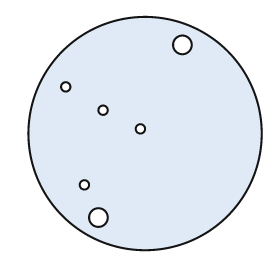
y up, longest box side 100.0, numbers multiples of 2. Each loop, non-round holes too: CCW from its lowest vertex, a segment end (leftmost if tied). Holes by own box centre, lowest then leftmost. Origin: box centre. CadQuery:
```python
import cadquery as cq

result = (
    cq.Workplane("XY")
    .moveTo(0.0, 0.0)
    .circle(50.0)
    .moveTo(-20.0, -36.0)
    .circle(4.0)
    .moveTo(-26.0, -22.0)
    .circle(2.0)
    .moveTo(-2.0, 2.0)
    .circle(2.0)
    .moveTo(-18.0, 10.0)
    .circle(2.0)
    .moveTo(-34.0, 20.0)
    .circle(2.0)
    .moveTo(16.0, 38.0)
    .circle(4.0)
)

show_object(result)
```